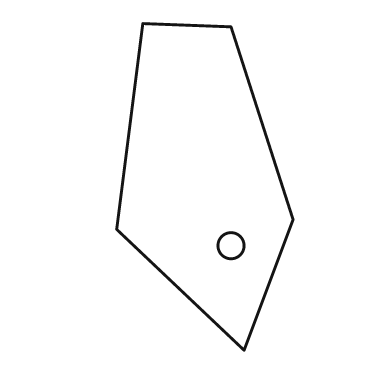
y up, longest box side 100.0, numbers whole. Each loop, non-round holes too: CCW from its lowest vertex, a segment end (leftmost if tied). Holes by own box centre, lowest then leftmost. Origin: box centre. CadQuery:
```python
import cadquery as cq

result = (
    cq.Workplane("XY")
    .moveTo(12.0, -50.0)
    .lineTo(27.0, -10.0)
    .lineTo(8.0, 49.0)
    .lineTo(-19.0, 50.0)
    .lineTo(-27.0, -13.0)
    .close()
    .moveTo(8.0, -18.0)
    .circle(4.0)
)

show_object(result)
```